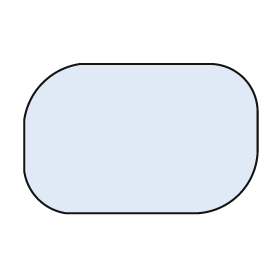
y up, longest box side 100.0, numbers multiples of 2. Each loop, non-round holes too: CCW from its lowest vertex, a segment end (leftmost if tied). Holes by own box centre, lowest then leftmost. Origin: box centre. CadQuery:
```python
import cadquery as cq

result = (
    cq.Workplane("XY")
    .moveTo(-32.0, -32.0)
    .lineTo(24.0, -32.0)
    .threePointArc((42.0, -24.0), (50.0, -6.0))
    .lineTo(50.0, 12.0)
    .threePointArc((44.0, 26.0), (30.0, 32.0))
    .lineTo(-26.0, 32.0)
    .threePointArc((-42.0, 24.0), (-50.0, 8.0))
    .lineTo(-50.0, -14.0)
    .threePointArc((-44.0, -26.0), (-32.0, -32.0))
    .close()
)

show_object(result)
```